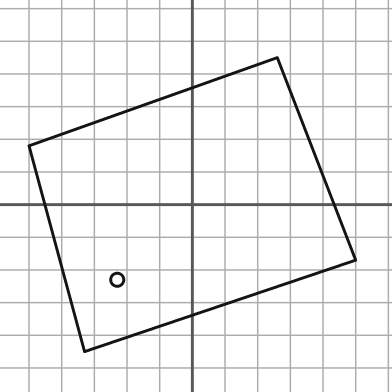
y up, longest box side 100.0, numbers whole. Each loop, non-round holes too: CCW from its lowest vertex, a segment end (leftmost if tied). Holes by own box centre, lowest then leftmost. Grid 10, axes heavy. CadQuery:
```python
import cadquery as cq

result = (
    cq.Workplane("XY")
    .moveTo(-33.0, -45.0)
    .lineTo(50.0, -17.0)
    .lineTo(26.0, 45.0)
    .lineTo(-50.0, 18.0)
    .close()
    .moveTo(-23.0, -23.0)
    .circle(2.0)
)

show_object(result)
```